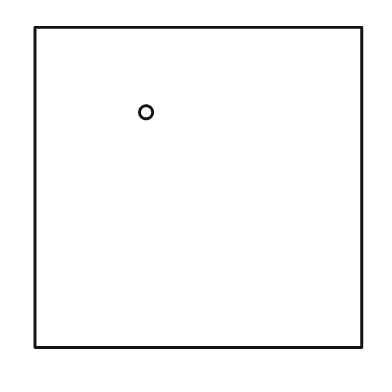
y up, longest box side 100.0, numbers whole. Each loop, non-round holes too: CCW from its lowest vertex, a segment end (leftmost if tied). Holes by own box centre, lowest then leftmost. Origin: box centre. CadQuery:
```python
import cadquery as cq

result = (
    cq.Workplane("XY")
    .moveTo(-50.0, -49.0)
    .lineTo(50.0, -49.0)
    .lineTo(50.0, 49.0)
    .lineTo(-50.0, 49.0)
    .close()
    .moveTo(-16.0, 23.0)
    .circle(2.0)
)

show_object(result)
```